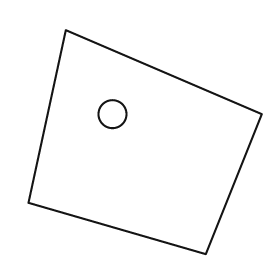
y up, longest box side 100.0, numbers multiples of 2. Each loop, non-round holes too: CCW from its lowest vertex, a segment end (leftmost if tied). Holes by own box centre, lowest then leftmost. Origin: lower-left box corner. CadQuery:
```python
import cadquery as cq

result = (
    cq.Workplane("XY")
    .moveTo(76.0, 0.0)
    .lineTo(100.0, 60.0)
    .lineTo(16.0, 96.0)
    .lineTo(0.0, 22.0)
    .close()
    .moveTo(36.0, 60.0)
    .circle(6.0)
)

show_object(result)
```